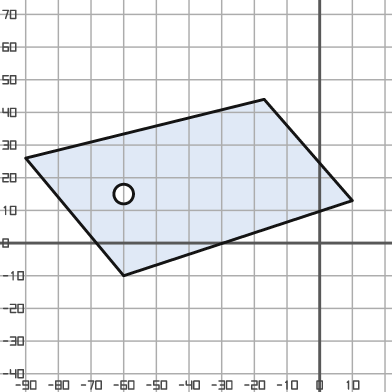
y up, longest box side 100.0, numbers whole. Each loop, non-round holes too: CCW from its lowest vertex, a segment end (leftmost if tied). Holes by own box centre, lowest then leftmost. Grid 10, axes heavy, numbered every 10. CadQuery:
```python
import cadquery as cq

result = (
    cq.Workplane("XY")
    .moveTo(-60.0, -10.0)
    .lineTo(10.0, 13.0)
    .lineTo(-17.0, 44.0)
    .lineTo(-90.0, 26.0)
    .close()
    .moveTo(-60.0, 15.0)
    .circle(3.0)
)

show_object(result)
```